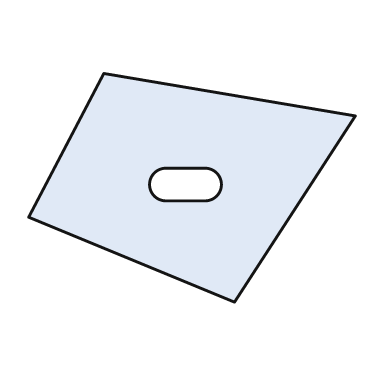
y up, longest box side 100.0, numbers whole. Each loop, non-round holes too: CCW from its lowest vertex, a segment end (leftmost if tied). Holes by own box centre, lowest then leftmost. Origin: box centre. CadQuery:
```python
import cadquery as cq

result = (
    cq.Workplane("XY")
    .moveTo(13.0, -35.0)
    .lineTo(50.0, 22.0)
    .lineTo(-27.0, 35.0)
    .lineTo(-50.0, -9.0)
    .close()
    .moveTo(-8.0, -4.0)
    .lineTo(4.0, -4.0)
    .threePointArc((9.0, 1.0), (4.0, 6.0))
    .lineTo(-8.0, 6.0)
    .threePointArc((-13.0, 1.0), (-8.0, -4.0))
    .close()
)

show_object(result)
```